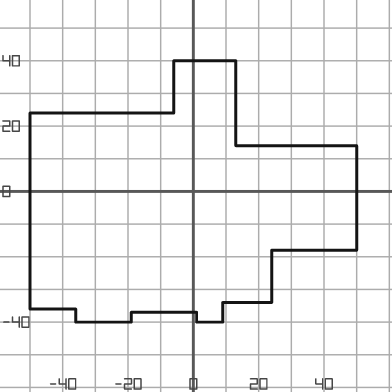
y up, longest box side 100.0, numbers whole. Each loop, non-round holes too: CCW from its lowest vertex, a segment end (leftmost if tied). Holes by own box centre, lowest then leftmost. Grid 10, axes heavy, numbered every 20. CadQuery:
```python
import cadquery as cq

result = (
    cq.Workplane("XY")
    .moveTo(-36.0, -40.0)
    .lineTo(-19.0, -40.0)
    .lineTo(-19.0, -37.0)
    .lineTo(1.0, -37.0)
    .lineTo(1.0, -40.0)
    .lineTo(9.0, -40.0)
    .lineTo(9.0, -34.0)
    .lineTo(24.0, -34.0)
    .lineTo(24.0, -18.0)
    .lineTo(50.0, -18.0)
    .lineTo(50.0, 14.0)
    .lineTo(13.0, 14.0)
    .lineTo(13.0, 40.0)
    .lineTo(-6.0, 40.0)
    .lineTo(-6.0, 24.0)
    .lineTo(-50.0, 24.0)
    .lineTo(-50.0, -36.0)
    .lineTo(-36.0, -36.0)
    .close()
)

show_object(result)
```